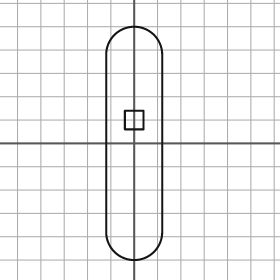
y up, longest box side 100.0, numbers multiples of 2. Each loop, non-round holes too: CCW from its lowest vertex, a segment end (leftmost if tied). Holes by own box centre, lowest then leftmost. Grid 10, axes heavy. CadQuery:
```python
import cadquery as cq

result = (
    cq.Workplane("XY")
    .moveTo(-12.0, -38.0)
    .threePointArc((0.0, -50.0), (12.0, -38.0))
    .lineTo(12.0, 38.0)
    .threePointArc((0.0, 50.0), (-12.0, 38.0))
    .close()
    .moveTo(-4.0, 6.0)
    .lineTo(4.0, 6.0)
    .lineTo(4.0, 14.0)
    .lineTo(-4.0, 14.0)
    .close()
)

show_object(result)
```